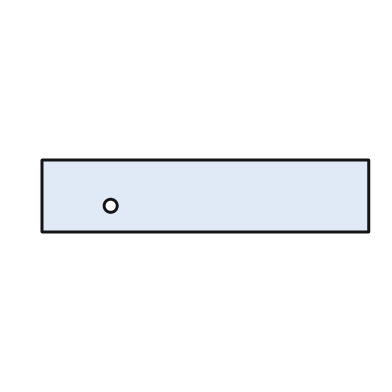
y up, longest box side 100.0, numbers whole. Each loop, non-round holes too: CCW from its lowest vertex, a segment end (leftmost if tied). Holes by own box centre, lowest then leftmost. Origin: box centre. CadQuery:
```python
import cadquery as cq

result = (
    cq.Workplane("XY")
    .moveTo(-50.0, -11.0)
    .lineTo(50.0, -11.0)
    .lineTo(50.0, 11.0)
    .lineTo(-50.0, 11.0)
    .close()
    .moveTo(-29.0, -3.0)
    .circle(2.0)
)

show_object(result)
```